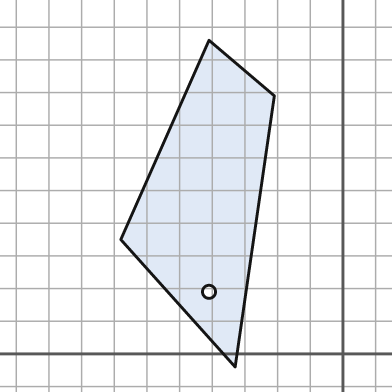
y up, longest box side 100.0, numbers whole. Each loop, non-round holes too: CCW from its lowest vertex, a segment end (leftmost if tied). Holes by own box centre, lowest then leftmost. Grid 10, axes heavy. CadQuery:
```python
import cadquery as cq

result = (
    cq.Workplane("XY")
    .moveTo(-33.0, -4.0)
    .lineTo(-21.0, 79.0)
    .lineTo(-41.0, 96.0)
    .lineTo(-68.0, 35.0)
    .close()
    .moveTo(-41.0, 19.0)
    .circle(2.0)
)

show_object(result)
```